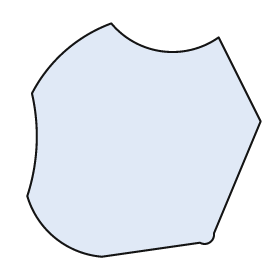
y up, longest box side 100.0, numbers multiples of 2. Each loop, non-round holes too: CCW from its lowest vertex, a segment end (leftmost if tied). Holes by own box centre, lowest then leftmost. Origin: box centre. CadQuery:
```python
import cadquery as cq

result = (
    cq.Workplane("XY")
    .moveTo(-18.0, -50.0)
    .lineTo(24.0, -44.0)
    .threePointArc((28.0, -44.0), (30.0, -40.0))
    .lineTo(50.0, 8.0)
    .lineTo(32.0, 44.0)
    .threePointArc((8.0, 38.0), (-14.0, 50.0))
    .threePointArc((-34.0, 38.0), (-48.0, 20.0))
    .threePointArc((-46.0, -2.0), (-50.0, -24.0))
    .threePointArc((-38.0, -42.0), (-18.0, -50.0))
    .close()
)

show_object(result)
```